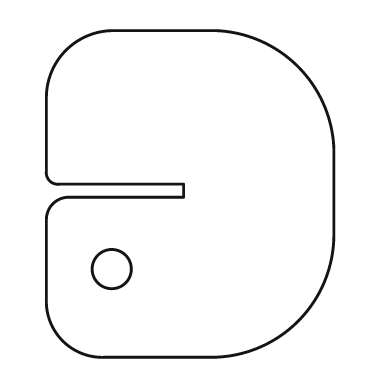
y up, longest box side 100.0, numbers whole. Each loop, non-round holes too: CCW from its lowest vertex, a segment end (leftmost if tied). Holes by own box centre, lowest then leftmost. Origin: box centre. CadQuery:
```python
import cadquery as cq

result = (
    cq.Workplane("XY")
    .moveTo(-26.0, -50.0)
    .lineTo(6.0, -50.0)
    .threePointArc((33.0, -39.0), (44.0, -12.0))
    .lineTo(44.0, 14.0)
    .threePointArc((33.0, 39.0), (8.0, 50.0))
    .lineTo(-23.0, 50.0)
    .threePointArc((-38.0, 44.0), (-44.0, 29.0))
    .lineTo(-44.0, 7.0)
    .threePointArc((-43.0, 4.0), (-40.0, 3.0))
    .lineTo(-2.0, 3.0)
    .lineTo(-2.0, -1.0)
    .lineTo(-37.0, -1.0)
    .threePointArc((-42.0, -3.0), (-44.0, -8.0))
    .lineTo(-44.0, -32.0)
    .threePointArc((-39.0, -45.0), (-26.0, -50.0))
    .close()
    .moveTo(-24.0, -23.0)
    .circle(6.0)
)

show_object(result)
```